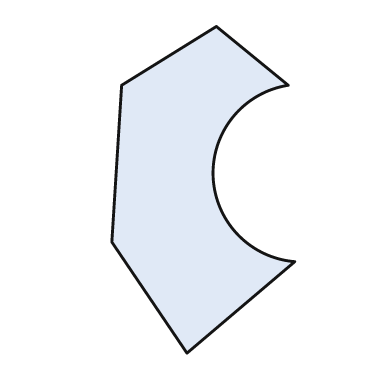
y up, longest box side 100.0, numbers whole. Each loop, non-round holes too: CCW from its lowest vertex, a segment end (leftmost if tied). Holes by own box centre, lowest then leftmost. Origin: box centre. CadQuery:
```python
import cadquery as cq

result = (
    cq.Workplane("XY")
    .moveTo(-5.0, -50.0)
    .lineTo(28.0, -22.0)
    .threePointArc((3.0, 4.0), (26.0, 32.0))
    .lineTo(4.0, 50.0)
    .lineTo(-25.0, 32.0)
    .lineTo(-28.0, -16.0)
    .close()
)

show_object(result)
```